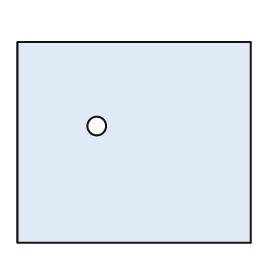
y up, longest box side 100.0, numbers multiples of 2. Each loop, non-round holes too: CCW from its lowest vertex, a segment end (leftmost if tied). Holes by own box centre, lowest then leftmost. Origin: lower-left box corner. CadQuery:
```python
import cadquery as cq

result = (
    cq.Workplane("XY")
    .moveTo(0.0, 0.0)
    .lineTo(100.0, 0.0)
    .lineTo(100.0, 86.0)
    .lineTo(0.0, 86.0)
    .close()
    .moveTo(34.0, 50.0)
    .circle(4.0)
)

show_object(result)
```